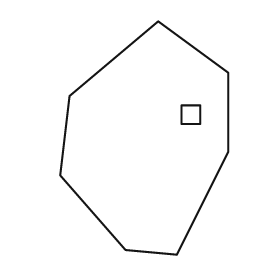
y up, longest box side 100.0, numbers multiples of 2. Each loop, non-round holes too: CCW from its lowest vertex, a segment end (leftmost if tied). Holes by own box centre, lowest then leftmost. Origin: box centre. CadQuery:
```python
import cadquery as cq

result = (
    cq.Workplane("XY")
    .moveTo(14.0, -50.0)
    .lineTo(36.0, -6.0)
    .lineTo(36.0, 28.0)
    .lineTo(6.0, 50.0)
    .lineTo(-32.0, 18.0)
    .lineTo(-36.0, -16.0)
    .lineTo(-8.0, -48.0)
    .close()
    .moveTo(16.0, 6.0)
    .lineTo(24.0, 6.0)
    .lineTo(24.0, 14.0)
    .lineTo(16.0, 14.0)
    .close()
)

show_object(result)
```